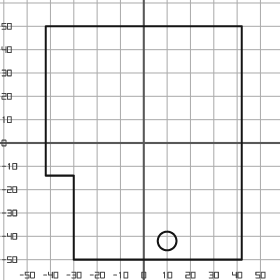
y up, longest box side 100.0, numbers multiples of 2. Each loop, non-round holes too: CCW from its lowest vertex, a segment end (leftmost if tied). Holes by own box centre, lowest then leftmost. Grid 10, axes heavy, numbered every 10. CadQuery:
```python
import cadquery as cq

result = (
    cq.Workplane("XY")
    .moveTo(-30.0, -50.0)
    .lineTo(42.0, -50.0)
    .lineTo(42.0, 50.0)
    .lineTo(-42.0, 50.0)
    .lineTo(-42.0, -14.0)
    .lineTo(-30.0, -14.0)
    .close()
    .moveTo(10.0, -42.0)
    .circle(4.0)
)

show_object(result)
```